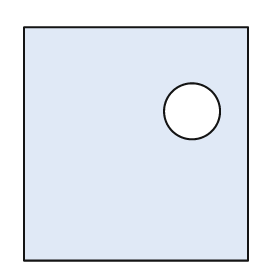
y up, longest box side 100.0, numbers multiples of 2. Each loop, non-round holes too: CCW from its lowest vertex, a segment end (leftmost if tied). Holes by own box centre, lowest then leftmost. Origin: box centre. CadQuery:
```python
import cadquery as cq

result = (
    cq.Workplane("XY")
    .moveTo(-48.0, -50.0)
    .lineTo(48.0, -50.0)
    .lineTo(48.0, 50.0)
    .lineTo(-48.0, 50.0)
    .close()
    .moveTo(24.0, 14.0)
    .circle(12.0)
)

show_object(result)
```